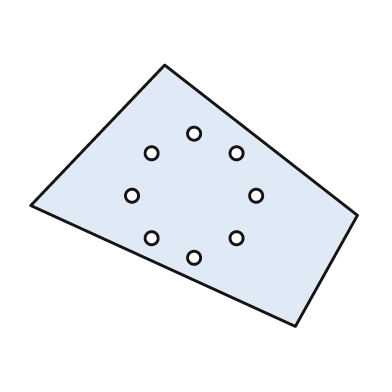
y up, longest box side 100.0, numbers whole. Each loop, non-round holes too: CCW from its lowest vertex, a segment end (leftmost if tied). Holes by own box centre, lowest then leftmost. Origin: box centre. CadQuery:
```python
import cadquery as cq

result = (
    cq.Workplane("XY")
    .moveTo(31.0, -40.0)
    .lineTo(50.0, -6.0)
    .lineTo(-9.0, 40.0)
    .lineTo(-50.0, -3.0)
    .close()
    .moveTo(0.0, -19.0)
    .circle(2.0)
    .moveTo(-13.0, -13.0)
    .circle(2.0)
    .moveTo(13.0, -13.0)
    .circle(2.0)
    .moveTo(-19.0, 0.0)
    .circle(2.0)
    .moveTo(19.0, 0.0)
    .circle(2.0)
    .moveTo(-13.0, 13.0)
    .circle(2.0)
    .moveTo(13.0, 13.0)
    .circle(2.0)
    .moveTo(0.0, 19.0)
    .circle(2.0)
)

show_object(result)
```